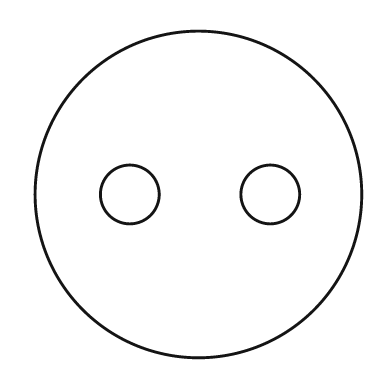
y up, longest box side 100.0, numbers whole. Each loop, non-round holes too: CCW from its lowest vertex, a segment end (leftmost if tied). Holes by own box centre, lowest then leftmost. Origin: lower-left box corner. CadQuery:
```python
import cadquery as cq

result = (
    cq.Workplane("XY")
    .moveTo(50.0, 50.0)
    .circle(50.0)
    .moveTo(29.0, 50.0)
    .circle(9.0)
    .moveTo(72.0, 50.0)
    .circle(9.0)
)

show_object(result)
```